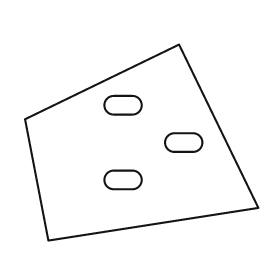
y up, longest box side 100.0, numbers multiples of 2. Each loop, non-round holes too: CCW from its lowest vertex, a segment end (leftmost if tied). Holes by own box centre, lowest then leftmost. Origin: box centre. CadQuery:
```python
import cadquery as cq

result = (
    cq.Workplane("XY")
    .moveTo(-40.0, -42.0)
    .lineTo(50.0, -28.0)
    .lineTo(16.0, 42.0)
    .lineTo(-50.0, 10.0)
    .close()
    .moveTo(-12.0, -20.0)
    .lineTo(-4.0, -20.0)
    .threePointArc((0.0, -16.0), (-4.0, -12.0))
    .lineTo(-12.0, -12.0)
    .threePointArc((-16.0, -16.0), (-12.0, -20.0))
    .close()
    .moveTo(14.0, -4.0)
    .lineTo(22.0, -4.0)
    .threePointArc((26.0, 0.0), (22.0, 4.0))
    .lineTo(14.0, 4.0)
    .threePointArc((10.0, 0.0), (14.0, -4.0))
    .close()
    .moveTo(-12.0, 12.0)
    .lineTo(-4.0, 12.0)
    .threePointArc((0.0, 16.0), (-4.0, 20.0))
    .lineTo(-12.0, 20.0)
    .threePointArc((-16.0, 16.0), (-12.0, 12.0))
    .close()
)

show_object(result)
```